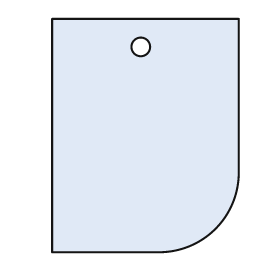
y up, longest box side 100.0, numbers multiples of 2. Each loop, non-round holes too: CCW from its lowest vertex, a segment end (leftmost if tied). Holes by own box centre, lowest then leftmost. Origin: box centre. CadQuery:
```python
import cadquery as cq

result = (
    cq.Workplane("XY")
    .moveTo(-40.0, -50.0)
    .lineTo(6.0, -50.0)
    .threePointArc((30.0, -40.0), (40.0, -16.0))
    .lineTo(40.0, 50.0)
    .lineTo(-40.0, 50.0)
    .close()
    .moveTo(-2.0, 38.0)
    .circle(4.0)
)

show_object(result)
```